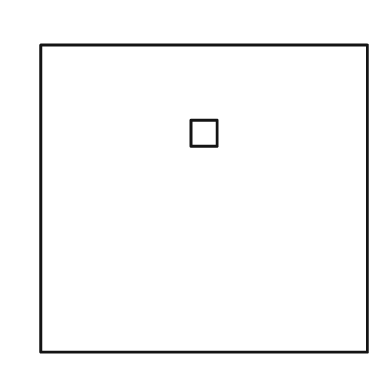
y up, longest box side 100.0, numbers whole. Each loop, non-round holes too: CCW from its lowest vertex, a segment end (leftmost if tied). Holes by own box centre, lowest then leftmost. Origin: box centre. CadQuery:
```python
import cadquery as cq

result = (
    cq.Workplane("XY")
    .moveTo(-50.0, -47.0)
    .lineTo(50.0, -47.0)
    .lineTo(50.0, 47.0)
    .lineTo(-50.0, 47.0)
    .close()
    .moveTo(-4.0, 16.0)
    .lineTo(4.0, 16.0)
    .lineTo(4.0, 24.0)
    .lineTo(-4.0, 24.0)
    .close()
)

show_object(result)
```